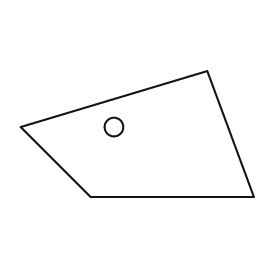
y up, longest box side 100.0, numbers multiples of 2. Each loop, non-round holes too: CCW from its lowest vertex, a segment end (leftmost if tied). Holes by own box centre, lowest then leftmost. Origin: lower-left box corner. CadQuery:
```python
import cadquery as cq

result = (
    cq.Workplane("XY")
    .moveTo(30.0, 0.0)
    .lineTo(100.0, 0.0)
    .lineTo(80.0, 54.0)
    .lineTo(0.0, 30.0)
    .close()
    .moveTo(40.0, 30.0)
    .circle(4.0)
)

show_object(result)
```